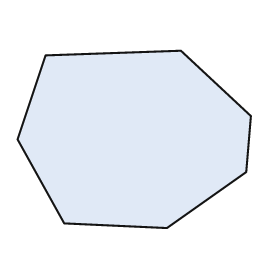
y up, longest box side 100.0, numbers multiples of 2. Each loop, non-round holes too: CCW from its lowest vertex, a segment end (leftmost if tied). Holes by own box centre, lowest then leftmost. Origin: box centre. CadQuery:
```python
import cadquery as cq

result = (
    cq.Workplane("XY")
    .moveTo(14.0, -38.0)
    .lineTo(48.0, -14.0)
    .lineTo(50.0, 10.0)
    .lineTo(20.0, 38.0)
    .lineTo(-38.0, 36.0)
    .lineTo(-50.0, 0.0)
    .lineTo(-30.0, -36.0)
    .close()
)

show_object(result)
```